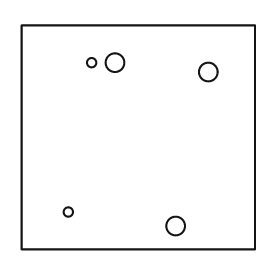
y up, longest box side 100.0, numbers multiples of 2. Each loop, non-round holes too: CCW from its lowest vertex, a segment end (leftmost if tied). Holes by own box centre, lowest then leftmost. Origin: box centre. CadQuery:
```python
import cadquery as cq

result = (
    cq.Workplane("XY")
    .moveTo(-50.0, -48.0)
    .lineTo(50.0, -48.0)
    .lineTo(50.0, 48.0)
    .lineTo(-50.0, 48.0)
    .close()
    .moveTo(16.0, -38.0)
    .circle(4.0)
    .moveTo(-30.0, -32.0)
    .circle(2.0)
    .moveTo(30.0, 28.0)
    .circle(4.0)
    .moveTo(-20.0, 32.0)
    .circle(2.0)
    .moveTo(-10.0, 32.0)
    .circle(4.0)
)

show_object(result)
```